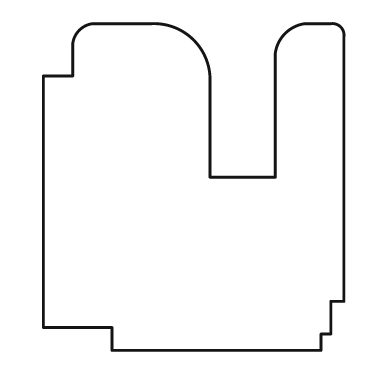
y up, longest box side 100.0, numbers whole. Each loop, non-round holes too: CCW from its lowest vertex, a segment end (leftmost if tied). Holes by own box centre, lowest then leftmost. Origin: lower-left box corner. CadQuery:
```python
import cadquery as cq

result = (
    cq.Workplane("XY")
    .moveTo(21.0, 0.0)
    .lineTo(85.0, 0.0)
    .lineTo(85.0, 5.0)
    .lineTo(88.0, 5.0)
    .lineTo(88.0, 15.0)
    .lineTo(92.0, 15.0)
    .lineTo(92.0, 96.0)
    .threePointArc((91.0, 99.0), (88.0, 100.0))
    .lineTo(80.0, 100.0)
    .threePointArc((74.0, 97.0), (71.0, 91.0))
    .lineTo(71.0, 53.0)
    .lineTo(51.0, 53.0)
    .lineTo(51.0, 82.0)
    .threePointArc((46.0, 95.0), (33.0, 100.0))
    .lineTo(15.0, 100.0)
    .threePointArc((11.0, 98.0), (9.0, 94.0))
    .lineTo(9.0, 84.0)
    .lineTo(0.0, 84.0)
    .lineTo(0.0, 7.0)
    .lineTo(21.0, 7.0)
    .close()
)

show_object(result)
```